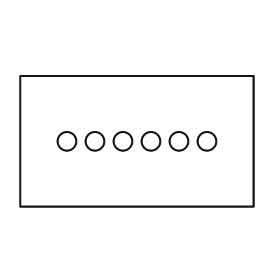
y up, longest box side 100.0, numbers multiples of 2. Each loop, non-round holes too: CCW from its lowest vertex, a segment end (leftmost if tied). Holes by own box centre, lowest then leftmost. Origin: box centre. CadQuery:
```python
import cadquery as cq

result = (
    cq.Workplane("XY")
    .moveTo(-50.0, -28.0)
    .lineTo(50.0, -28.0)
    .lineTo(50.0, 28.0)
    .lineTo(-50.0, 28.0)
    .close()
    .moveTo(-30.0, 0.0)
    .circle(4.0)
    .moveTo(-18.0, 0.0)
    .circle(4.0)
    .moveTo(-6.0, 0.0)
    .circle(4.0)
    .moveTo(6.0, 0.0)
    .circle(4.0)
    .moveTo(18.0, 0.0)
    .circle(4.0)
    .moveTo(30.0, 0.0)
    .circle(4.0)
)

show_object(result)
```